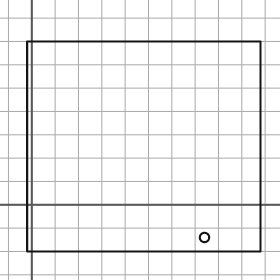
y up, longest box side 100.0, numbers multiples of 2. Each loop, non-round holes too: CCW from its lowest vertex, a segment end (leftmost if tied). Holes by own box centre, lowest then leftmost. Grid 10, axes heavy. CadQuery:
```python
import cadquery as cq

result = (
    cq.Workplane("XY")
    .moveTo(-2.0, -20.0)
    .lineTo(98.0, -20.0)
    .lineTo(98.0, 70.0)
    .lineTo(-2.0, 70.0)
    .close()
    .moveTo(74.0, -14.0)
    .circle(2.0)
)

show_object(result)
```